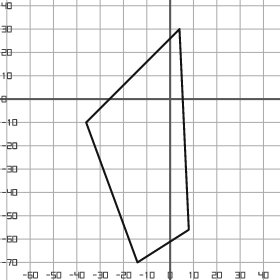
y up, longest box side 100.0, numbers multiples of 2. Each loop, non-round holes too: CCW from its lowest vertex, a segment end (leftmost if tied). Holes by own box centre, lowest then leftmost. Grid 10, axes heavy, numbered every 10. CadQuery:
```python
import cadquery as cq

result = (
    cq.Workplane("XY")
    .moveTo(-14.0, -70.0)
    .lineTo(8.0, -56.0)
    .lineTo(4.0, 30.0)
    .lineTo(-36.0, -10.0)
    .close()
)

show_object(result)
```